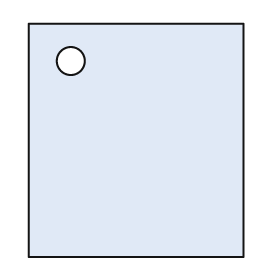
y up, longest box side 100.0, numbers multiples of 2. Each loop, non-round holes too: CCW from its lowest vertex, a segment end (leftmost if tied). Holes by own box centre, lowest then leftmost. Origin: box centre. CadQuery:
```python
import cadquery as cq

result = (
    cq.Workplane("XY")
    .moveTo(-46.0, -50.0)
    .lineTo(46.0, -50.0)
    .lineTo(46.0, 50.0)
    .lineTo(-46.0, 50.0)
    .close()
    .moveTo(-28.0, 34.0)
    .circle(6.0)
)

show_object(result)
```